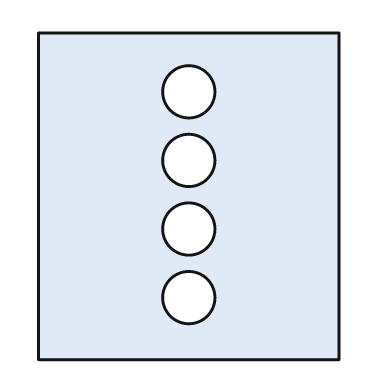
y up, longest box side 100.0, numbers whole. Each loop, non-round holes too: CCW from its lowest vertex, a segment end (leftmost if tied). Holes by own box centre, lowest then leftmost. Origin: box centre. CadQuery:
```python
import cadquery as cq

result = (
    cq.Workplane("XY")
    .moveTo(-46.0, -50.0)
    .lineTo(46.0, -50.0)
    .lineTo(46.0, 50.0)
    .lineTo(-46.0, 50.0)
    .close()
    .moveTo(0.0, -31.0)
    .circle(8.0)
    .moveTo(0.0, -10.0)
    .circle(8.0)
    .moveTo(0.0, 11.0)
    .circle(8.0)
    .moveTo(0.0, 32.0)
    .circle(8.0)
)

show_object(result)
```